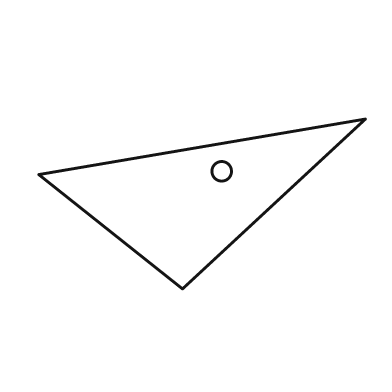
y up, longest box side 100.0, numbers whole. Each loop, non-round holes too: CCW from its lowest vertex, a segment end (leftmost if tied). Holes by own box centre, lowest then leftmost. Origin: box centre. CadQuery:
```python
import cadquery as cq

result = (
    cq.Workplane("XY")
    .moveTo(-6.0, -26.0)
    .lineTo(50.0, 26.0)
    .lineTo(-50.0, 9.0)
    .close()
    .moveTo(6.0, 10.0)
    .circle(3.0)
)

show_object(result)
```